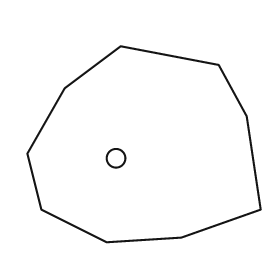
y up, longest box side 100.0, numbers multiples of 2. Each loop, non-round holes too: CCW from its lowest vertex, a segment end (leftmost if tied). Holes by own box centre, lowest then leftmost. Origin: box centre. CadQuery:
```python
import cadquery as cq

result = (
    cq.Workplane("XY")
    .moveTo(-16.0, -42.0)
    .lineTo(16.0, -40.0)
    .lineTo(50.0, -28.0)
    .lineTo(44.0, 12.0)
    .lineTo(32.0, 34.0)
    .lineTo(-10.0, 42.0)
    .lineTo(-34.0, 24.0)
    .lineTo(-50.0, -4.0)
    .lineTo(-44.0, -28.0)
    .close()
    .moveTo(-12.0, -6.0)
    .circle(4.0)
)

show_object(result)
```